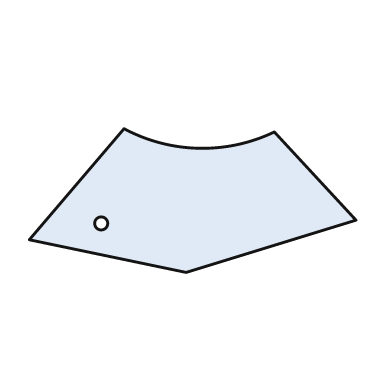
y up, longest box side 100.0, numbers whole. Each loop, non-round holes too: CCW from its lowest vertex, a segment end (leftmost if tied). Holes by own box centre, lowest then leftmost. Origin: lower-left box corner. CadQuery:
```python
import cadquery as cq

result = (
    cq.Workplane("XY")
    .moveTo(48.0, 0.0)
    .lineTo(100.0, 16.0)
    .lineTo(75.0, 43.0)
    .threePointArc((52.0, 38.0), (29.0, 44.0))
    .lineTo(0.0, 10.0)
    .close()
    .moveTo(22.0, 15.0)
    .circle(2.0)
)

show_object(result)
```